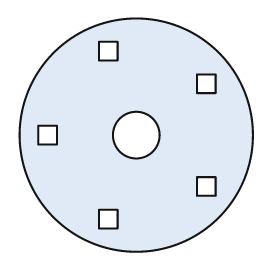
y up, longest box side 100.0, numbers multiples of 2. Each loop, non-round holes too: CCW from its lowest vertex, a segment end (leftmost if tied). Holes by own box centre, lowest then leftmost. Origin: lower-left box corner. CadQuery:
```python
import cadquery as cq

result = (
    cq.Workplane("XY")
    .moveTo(50.0, 50.0)
    .circle(50.0)
    .moveTo(34.0, 10.0)
    .lineTo(42.0, 10.0)
    .lineTo(42.0, 18.0)
    .lineTo(34.0, 18.0)
    .close()
    .moveTo(76.0, 24.0)
    .lineTo(84.0, 24.0)
    .lineTo(84.0, 32.0)
    .lineTo(76.0, 32.0)
    .close()
    .moveTo(8.0, 46.0)
    .lineTo(16.0, 46.0)
    .lineTo(16.0, 54.0)
    .lineTo(8.0, 54.0)
    .close()
    .moveTo(50.0, 50.0)
    .circle(10.0)
    .moveTo(76.0, 68.0)
    .lineTo(84.0, 68.0)
    .lineTo(84.0, 76.0)
    .lineTo(76.0, 76.0)
    .close()
    .moveTo(34.0, 82.0)
    .lineTo(42.0, 82.0)
    .lineTo(42.0, 90.0)
    .lineTo(34.0, 90.0)
    .close()
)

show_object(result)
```